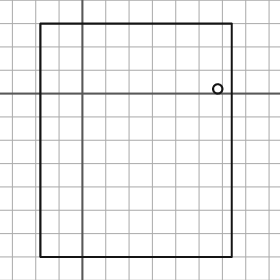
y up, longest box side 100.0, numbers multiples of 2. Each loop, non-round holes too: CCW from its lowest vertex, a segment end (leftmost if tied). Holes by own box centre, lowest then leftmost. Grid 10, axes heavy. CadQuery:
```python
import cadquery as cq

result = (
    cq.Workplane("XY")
    .moveTo(-18.0, -70.0)
    .lineTo(64.0, -70.0)
    .lineTo(64.0, 30.0)
    .lineTo(-18.0, 30.0)
    .close()
    .moveTo(58.0, 2.0)
    .circle(2.0)
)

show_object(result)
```